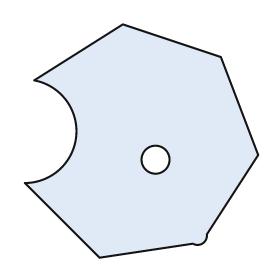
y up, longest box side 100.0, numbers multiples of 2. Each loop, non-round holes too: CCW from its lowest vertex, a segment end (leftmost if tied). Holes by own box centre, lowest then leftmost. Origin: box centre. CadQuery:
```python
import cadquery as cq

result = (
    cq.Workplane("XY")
    .moveTo(-18.0, -50.0)
    .lineTo(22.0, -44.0)
    .threePointArc((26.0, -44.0), (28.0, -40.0))
    .lineTo(50.0, -6.0)
    .lineTo(34.0, 36.0)
    .lineTo(-8.0, 50.0)
    .lineTo(-46.0, 26.0)
    .threePointArc((-28.0, 2.0), (-50.0, -18.0))
    .close()
    .moveTo(6.0, -8.0)
    .circle(6.0)
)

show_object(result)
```